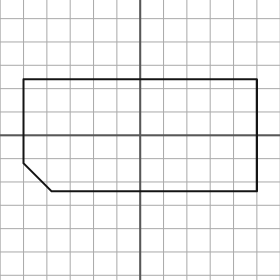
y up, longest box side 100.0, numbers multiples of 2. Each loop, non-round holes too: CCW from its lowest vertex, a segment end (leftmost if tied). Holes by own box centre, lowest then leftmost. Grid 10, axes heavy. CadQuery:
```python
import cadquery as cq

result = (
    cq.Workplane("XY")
    .moveTo(-38.0, -24.0)
    .lineTo(50.0, -24.0)
    .lineTo(50.0, 24.0)
    .lineTo(-50.0, 24.0)
    .lineTo(-50.0, -12.0)
    .close()
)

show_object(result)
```